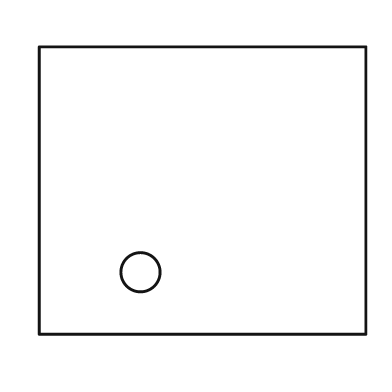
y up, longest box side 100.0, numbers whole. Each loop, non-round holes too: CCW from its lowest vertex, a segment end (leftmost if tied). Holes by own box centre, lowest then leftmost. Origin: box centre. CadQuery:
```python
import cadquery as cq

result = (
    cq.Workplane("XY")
    .moveTo(-50.0, -44.0)
    .lineTo(50.0, -44.0)
    .lineTo(50.0, 44.0)
    .lineTo(-50.0, 44.0)
    .close()
    .moveTo(-19.0, -25.0)
    .circle(6.0)
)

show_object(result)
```